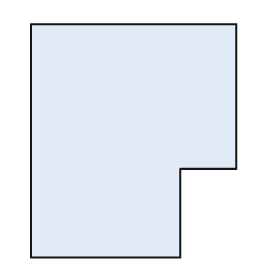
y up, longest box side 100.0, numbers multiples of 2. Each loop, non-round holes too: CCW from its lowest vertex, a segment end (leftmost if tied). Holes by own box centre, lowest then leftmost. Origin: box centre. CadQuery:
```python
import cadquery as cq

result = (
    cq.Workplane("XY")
    .moveTo(-44.0, -50.0)
    .lineTo(20.0, -50.0)
    .lineTo(20.0, -12.0)
    .lineTo(44.0, -12.0)
    .lineTo(44.0, 50.0)
    .lineTo(-44.0, 50.0)
    .close()
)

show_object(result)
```